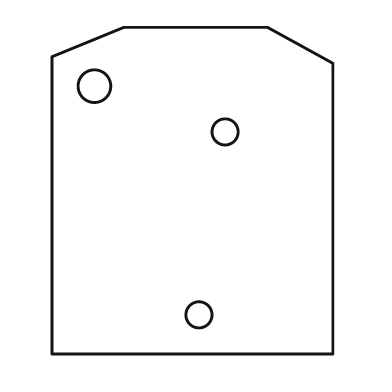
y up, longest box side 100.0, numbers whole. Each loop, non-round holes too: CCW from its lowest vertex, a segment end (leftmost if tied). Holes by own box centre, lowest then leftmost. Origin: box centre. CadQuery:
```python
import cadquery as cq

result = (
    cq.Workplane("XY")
    .moveTo(-43.0, -50.0)
    .lineTo(43.0, -50.0)
    .lineTo(43.0, 39.0)
    .lineTo(23.0, 50.0)
    .lineTo(-21.0, 50.0)
    .lineTo(-43.0, 41.0)
    .close()
    .moveTo(2.0, -38.0)
    .circle(4.0)
    .moveTo(10.0, 18.0)
    .circle(4.0)
    .moveTo(-30.0, 32.0)
    .circle(5.0)
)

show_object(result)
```